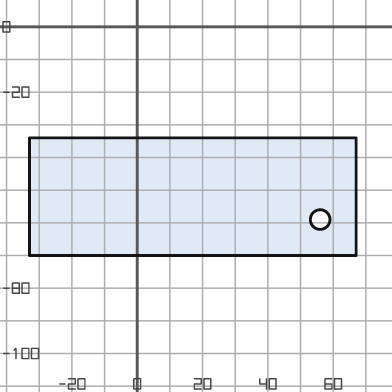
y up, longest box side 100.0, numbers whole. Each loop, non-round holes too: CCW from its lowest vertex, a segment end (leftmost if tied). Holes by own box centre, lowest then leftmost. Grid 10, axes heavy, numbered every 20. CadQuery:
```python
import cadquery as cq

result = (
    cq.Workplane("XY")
    .moveTo(-33.0, -70.0)
    .lineTo(67.0, -70.0)
    .lineTo(67.0, -34.0)
    .lineTo(-33.0, -34.0)
    .close()
    .moveTo(56.0, -59.0)
    .circle(3.0)
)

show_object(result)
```